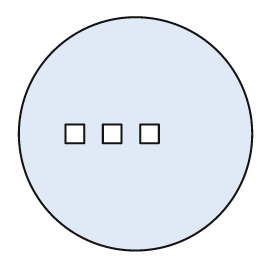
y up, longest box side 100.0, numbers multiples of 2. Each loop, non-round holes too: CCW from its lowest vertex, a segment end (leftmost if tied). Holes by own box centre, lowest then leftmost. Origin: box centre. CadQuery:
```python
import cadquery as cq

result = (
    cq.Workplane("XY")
    .moveTo(0.0, 0.0)
    .circle(50.0)
    .moveTo(-30.0, -4.0)
    .lineTo(-22.0, -4.0)
    .lineTo(-22.0, 4.0)
    .lineTo(-30.0, 4.0)
    .close()
    .moveTo(-14.0, -4.0)
    .lineTo(-6.0, -4.0)
    .lineTo(-6.0, 4.0)
    .lineTo(-14.0, 4.0)
    .close()
    .moveTo(2.0, -4.0)
    .lineTo(10.0, -4.0)
    .lineTo(10.0, 4.0)
    .lineTo(2.0, 4.0)
    .close()
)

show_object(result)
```